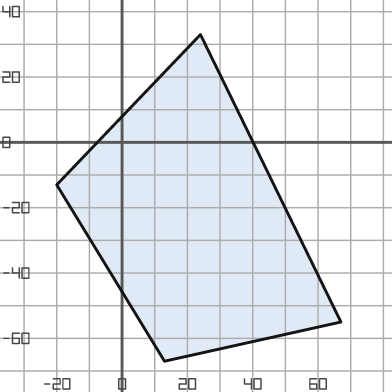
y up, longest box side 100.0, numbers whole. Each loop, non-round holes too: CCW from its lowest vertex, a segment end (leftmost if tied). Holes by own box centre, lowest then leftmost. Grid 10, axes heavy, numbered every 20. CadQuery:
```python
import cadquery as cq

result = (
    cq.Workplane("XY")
    .moveTo(13.0, -67.0)
    .lineTo(67.0, -55.0)
    .lineTo(24.0, 33.0)
    .lineTo(-20.0, -13.0)
    .close()
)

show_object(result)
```